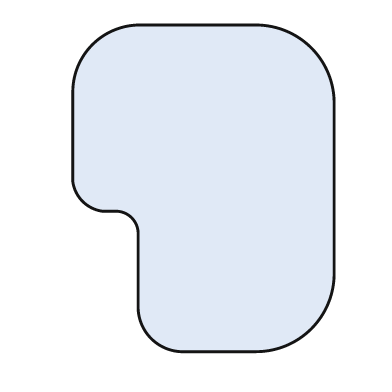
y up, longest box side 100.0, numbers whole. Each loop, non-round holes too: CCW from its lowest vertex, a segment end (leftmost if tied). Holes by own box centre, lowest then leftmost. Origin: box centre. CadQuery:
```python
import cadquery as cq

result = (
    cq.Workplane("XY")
    .moveTo(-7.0, -50.0)
    .lineTo(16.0, -50.0)
    .threePointArc((33.0, -43.0), (40.0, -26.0))
    .lineTo(40.0, 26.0)
    .threePointArc((33.0, 43.0), (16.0, 50.0))
    .lineTo(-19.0, 50.0)
    .threePointArc((-34.0, 44.0), (-40.0, 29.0))
    .lineTo(-40.0, 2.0)
    .threePointArc((-37.0, -4.0), (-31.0, -7.0))
    .lineTo(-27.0, -7.0)
    .threePointArc((-22.0, -9.0), (-20.0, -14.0))
    .lineTo(-20.0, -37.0)
    .threePointArc((-16.0, -46.0), (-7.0, -50.0))
    .close()
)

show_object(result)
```